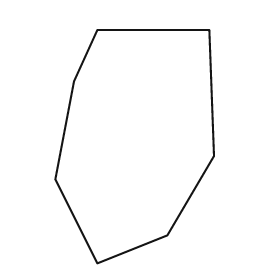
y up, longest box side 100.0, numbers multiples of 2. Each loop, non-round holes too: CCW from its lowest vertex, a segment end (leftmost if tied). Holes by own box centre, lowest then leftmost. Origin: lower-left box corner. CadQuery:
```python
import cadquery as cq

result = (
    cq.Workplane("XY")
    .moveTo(18.0, 0.0)
    .lineTo(48.0, 12.0)
    .lineTo(68.0, 46.0)
    .lineTo(66.0, 100.0)
    .lineTo(18.0, 100.0)
    .lineTo(8.0, 78.0)
    .lineTo(0.0, 36.0)
    .close()
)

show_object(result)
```